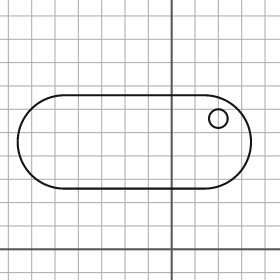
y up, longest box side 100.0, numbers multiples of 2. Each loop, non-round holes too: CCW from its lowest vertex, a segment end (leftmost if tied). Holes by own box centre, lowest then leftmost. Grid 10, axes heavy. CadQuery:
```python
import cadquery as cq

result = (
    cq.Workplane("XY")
    .moveTo(-46.0, 26.0)
    .lineTo(14.0, 26.0)
    .threePointArc((34.0, 46.0), (14.0, 66.0))
    .lineTo(-46.0, 66.0)
    .threePointArc((-66.0, 46.0), (-46.0, 26.0))
    .close()
    .moveTo(20.0, 56.0)
    .circle(4.0)
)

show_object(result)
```